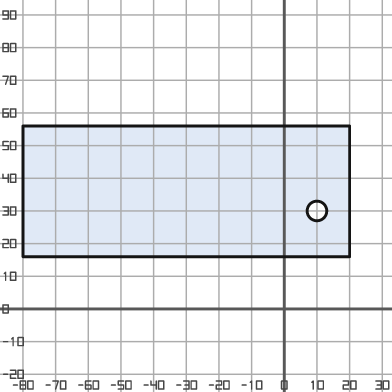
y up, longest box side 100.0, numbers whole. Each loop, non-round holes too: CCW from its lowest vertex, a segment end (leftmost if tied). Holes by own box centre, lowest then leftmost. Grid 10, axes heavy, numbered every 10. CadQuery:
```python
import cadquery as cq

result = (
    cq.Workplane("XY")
    .moveTo(-80.0, 16.0)
    .lineTo(20.0, 16.0)
    .lineTo(20.0, 56.0)
    .lineTo(-80.0, 56.0)
    .close()
    .moveTo(10.0, 30.0)
    .circle(3.0)
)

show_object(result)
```